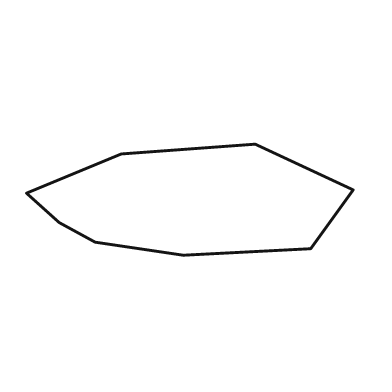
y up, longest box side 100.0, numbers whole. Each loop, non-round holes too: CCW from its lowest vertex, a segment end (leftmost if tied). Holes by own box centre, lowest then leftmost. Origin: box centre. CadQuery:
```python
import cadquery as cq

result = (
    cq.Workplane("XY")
    .moveTo(-2.0, -17.0)
    .lineTo(37.0, -15.0)
    .lineTo(50.0, 3.0)
    .lineTo(20.0, 17.0)
    .lineTo(-21.0, 14.0)
    .lineTo(-50.0, 2.0)
    .lineTo(-40.0, -7.0)
    .lineTo(-29.0, -13.0)
    .close()
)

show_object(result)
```